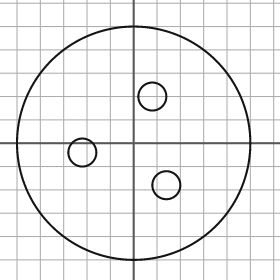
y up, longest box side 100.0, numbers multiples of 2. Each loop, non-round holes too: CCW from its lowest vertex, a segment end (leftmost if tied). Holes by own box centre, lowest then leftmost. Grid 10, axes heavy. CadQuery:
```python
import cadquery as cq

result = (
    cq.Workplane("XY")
    .moveTo(0.0, 0.0)
    .circle(50.0)
    .moveTo(14.0, -18.0)
    .circle(6.0)
    .moveTo(-22.0, -4.0)
    .circle(6.0)
    .moveTo(8.0, 20.0)
    .circle(6.0)
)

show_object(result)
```